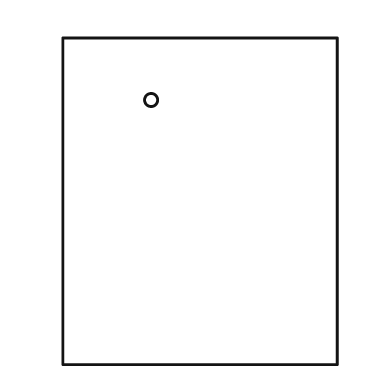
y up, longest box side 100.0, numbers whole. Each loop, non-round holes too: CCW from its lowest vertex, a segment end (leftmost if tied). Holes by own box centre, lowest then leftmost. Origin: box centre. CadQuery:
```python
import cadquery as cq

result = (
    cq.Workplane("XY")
    .moveTo(-42.0, -50.0)
    .lineTo(42.0, -50.0)
    .lineTo(42.0, 50.0)
    .lineTo(-42.0, 50.0)
    .close()
    .moveTo(-15.0, 31.0)
    .circle(2.0)
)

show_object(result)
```